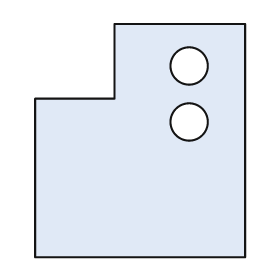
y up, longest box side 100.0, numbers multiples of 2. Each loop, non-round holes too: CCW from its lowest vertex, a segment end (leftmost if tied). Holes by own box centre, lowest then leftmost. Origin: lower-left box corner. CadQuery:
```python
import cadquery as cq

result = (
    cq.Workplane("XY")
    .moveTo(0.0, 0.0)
    .lineTo(90.0, 0.0)
    .lineTo(90.0, 100.0)
    .lineTo(34.0, 100.0)
    .lineTo(34.0, 68.0)
    .lineTo(0.0, 68.0)
    .close()
    .moveTo(66.0, 58.0)
    .circle(8.0)
    .moveTo(66.0, 82.0)
    .circle(8.0)
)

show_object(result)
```